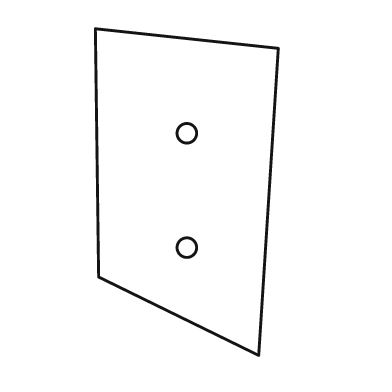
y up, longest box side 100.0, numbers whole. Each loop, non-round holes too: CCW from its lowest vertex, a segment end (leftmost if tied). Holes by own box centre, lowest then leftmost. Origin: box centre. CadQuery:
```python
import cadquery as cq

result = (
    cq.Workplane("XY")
    .moveTo(22.0, -50.0)
    .lineTo(28.0, 44.0)
    .lineTo(-28.0, 50.0)
    .lineTo(-27.0, -26.0)
    .close()
    .moveTo(0.0, -17.0)
    .circle(3.0)
    .moveTo(0.0, 18.0)
    .circle(3.0)
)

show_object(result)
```